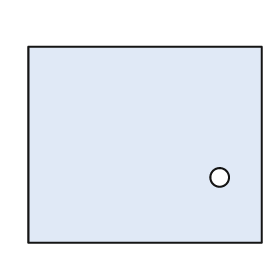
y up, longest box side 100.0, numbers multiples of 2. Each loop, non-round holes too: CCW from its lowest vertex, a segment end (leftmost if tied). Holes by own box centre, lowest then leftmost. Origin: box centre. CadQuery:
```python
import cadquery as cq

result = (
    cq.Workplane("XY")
    .moveTo(-50.0, -42.0)
    .lineTo(50.0, -42.0)
    .lineTo(50.0, 42.0)
    .lineTo(-50.0, 42.0)
    .close()
    .moveTo(32.0, -14.0)
    .circle(4.0)
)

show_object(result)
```